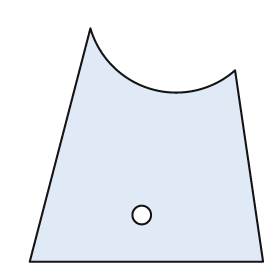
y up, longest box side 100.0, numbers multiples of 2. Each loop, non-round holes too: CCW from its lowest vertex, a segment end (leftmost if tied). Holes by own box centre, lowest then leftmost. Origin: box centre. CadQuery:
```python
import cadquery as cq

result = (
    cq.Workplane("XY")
    .moveTo(-50.0, -50.0)
    .lineTo(50.0, -50.0)
    .lineTo(38.0, 32.0)
    .threePointArc((2.0, 24.0), (-24.0, 50.0))
    .close()
    .moveTo(-2.0, -30.0)
    .circle(4.0)
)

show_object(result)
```